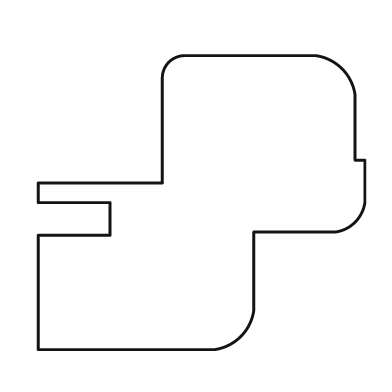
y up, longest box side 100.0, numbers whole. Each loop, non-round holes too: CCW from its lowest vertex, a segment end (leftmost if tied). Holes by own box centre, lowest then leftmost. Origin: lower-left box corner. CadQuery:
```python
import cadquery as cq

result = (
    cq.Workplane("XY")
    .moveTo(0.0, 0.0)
    .lineTo(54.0, 0.0)
    .threePointArc((62.0, 4.0), (66.0, 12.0))
    .lineTo(66.0, 36.0)
    .lineTo(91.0, 36.0)
    .threePointArc((97.0, 39.0), (100.0, 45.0))
    .lineTo(100.0, 58.0)
    .lineTo(97.0, 58.0)
    .lineTo(97.0, 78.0)
    .threePointArc((93.0, 86.0), (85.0, 90.0))
    .lineTo(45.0, 90.0)
    .threePointArc((40.0, 88.0), (38.0, 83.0))
    .lineTo(38.0, 51.0)
    .lineTo(0.0, 51.0)
    .lineTo(0.0, 45.0)
    .lineTo(22.0, 45.0)
    .lineTo(22.0, 35.0)
    .lineTo(0.0, 35.0)
    .close()
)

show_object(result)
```